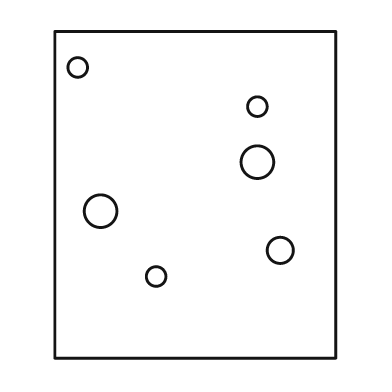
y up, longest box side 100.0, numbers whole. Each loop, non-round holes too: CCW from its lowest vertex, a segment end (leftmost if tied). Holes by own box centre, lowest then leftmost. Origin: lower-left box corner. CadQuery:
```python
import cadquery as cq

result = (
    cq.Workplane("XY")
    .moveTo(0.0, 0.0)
    .lineTo(86.0, 0.0)
    .lineTo(86.0, 100.0)
    .lineTo(0.0, 100.0)
    .close()
    .moveTo(31.0, 25.0)
    .circle(3.0)
    .moveTo(69.0, 33.0)
    .circle(4.0)
    .moveTo(14.0, 45.0)
    .circle(5.0)
    .moveTo(62.0, 60.0)
    .circle(5.0)
    .moveTo(62.0, 77.0)
    .circle(3.0)
    .moveTo(7.0, 89.0)
    .circle(3.0)
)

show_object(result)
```